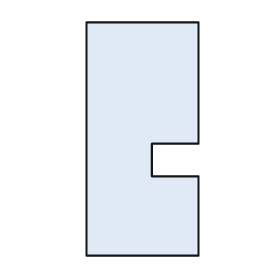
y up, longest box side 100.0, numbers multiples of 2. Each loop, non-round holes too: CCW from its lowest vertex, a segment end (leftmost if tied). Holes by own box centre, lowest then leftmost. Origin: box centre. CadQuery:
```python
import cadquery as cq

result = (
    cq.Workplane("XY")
    .moveTo(-24.0, -50.0)
    .lineTo(24.0, -50.0)
    .lineTo(24.0, -16.0)
    .lineTo(4.0, -16.0)
    .lineTo(4.0, -2.0)
    .lineTo(24.0, -2.0)
    .lineTo(24.0, 50.0)
    .lineTo(-24.0, 50.0)
    .close()
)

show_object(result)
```